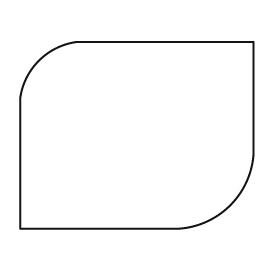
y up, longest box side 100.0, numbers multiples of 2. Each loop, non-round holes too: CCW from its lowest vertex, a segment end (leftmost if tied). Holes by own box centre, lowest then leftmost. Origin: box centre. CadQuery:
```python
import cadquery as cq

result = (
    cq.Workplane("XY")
    .moveTo(-50.0, -40.0)
    .lineTo(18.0, -40.0)
    .threePointArc((40.0, -30.0), (50.0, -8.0))
    .lineTo(50.0, 40.0)
    .lineTo(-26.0, 40.0)
    .threePointArc((-42.0, 32.0), (-50.0, 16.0))
    .close()
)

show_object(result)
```